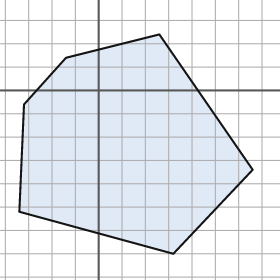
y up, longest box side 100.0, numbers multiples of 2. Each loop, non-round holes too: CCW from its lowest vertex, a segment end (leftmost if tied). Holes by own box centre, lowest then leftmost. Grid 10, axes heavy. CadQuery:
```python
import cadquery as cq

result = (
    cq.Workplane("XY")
    .moveTo(32.0, -70.0)
    .lineTo(66.0, -34.0)
    .lineTo(26.0, 24.0)
    .lineTo(-14.0, 14.0)
    .lineTo(-32.0, -6.0)
    .lineTo(-34.0, -52.0)
    .close()
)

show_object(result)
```